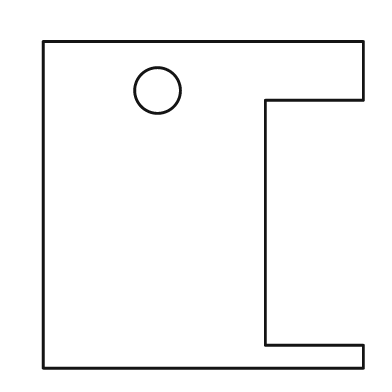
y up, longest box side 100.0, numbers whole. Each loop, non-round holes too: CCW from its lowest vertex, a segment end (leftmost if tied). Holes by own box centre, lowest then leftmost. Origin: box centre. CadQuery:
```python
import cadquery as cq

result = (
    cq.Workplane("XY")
    .moveTo(-49.0, -50.0)
    .lineTo(49.0, -50.0)
    .lineTo(49.0, -43.0)
    .lineTo(19.0, -43.0)
    .lineTo(19.0, 32.0)
    .lineTo(49.0, 32.0)
    .lineTo(49.0, 50.0)
    .lineTo(-49.0, 50.0)
    .close()
    .moveTo(-14.0, 35.0)
    .circle(7.0)
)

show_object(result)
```